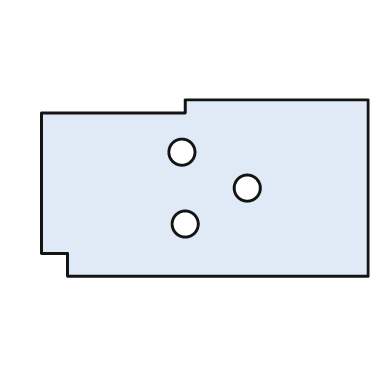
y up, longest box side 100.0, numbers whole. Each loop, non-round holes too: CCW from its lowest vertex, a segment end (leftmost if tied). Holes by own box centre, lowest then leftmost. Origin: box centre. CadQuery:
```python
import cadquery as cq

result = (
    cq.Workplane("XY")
    .moveTo(-42.0, -27.0)
    .lineTo(50.0, -27.0)
    .lineTo(50.0, 27.0)
    .lineTo(-6.0, 27.0)
    .lineTo(-6.0, 23.0)
    .lineTo(-50.0, 23.0)
    .lineTo(-50.0, -20.0)
    .lineTo(-42.0, -20.0)
    .close()
    .moveTo(-6.0, -11.0)
    .circle(4.0)
    .moveTo(13.0, 0.0)
    .circle(4.0)
    .moveTo(-7.0, 11.0)
    .circle(4.0)
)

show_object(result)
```